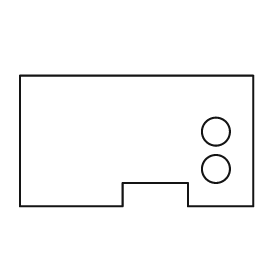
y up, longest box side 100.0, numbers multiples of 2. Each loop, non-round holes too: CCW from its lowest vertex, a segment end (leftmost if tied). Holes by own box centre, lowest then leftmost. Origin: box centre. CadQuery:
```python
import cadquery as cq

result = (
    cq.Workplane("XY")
    .moveTo(-50.0, -28.0)
    .lineTo(-6.0, -28.0)
    .lineTo(-6.0, -18.0)
    .lineTo(22.0, -18.0)
    .lineTo(22.0, -28.0)
    .lineTo(50.0, -28.0)
    .lineTo(50.0, 28.0)
    .lineTo(-50.0, 28.0)
    .close()
    .moveTo(34.0, -12.0)
    .circle(6.0)
    .moveTo(34.0, 4.0)
    .circle(6.0)
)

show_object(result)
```